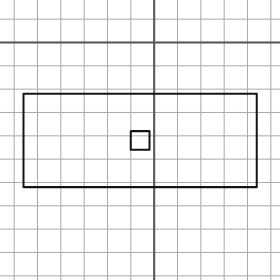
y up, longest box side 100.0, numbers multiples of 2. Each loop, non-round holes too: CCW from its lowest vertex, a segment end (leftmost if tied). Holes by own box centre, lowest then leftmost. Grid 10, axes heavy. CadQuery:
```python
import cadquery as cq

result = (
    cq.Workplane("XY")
    .moveTo(-56.0, -62.0)
    .lineTo(44.0, -62.0)
    .lineTo(44.0, -22.0)
    .lineTo(-56.0, -22.0)
    .close()
    .moveTo(-10.0, -46.0)
    .lineTo(-2.0, -46.0)
    .lineTo(-2.0, -38.0)
    .lineTo(-10.0, -38.0)
    .close()
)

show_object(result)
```